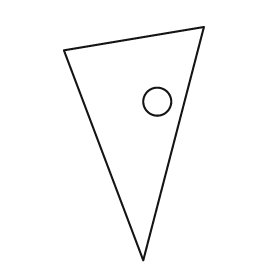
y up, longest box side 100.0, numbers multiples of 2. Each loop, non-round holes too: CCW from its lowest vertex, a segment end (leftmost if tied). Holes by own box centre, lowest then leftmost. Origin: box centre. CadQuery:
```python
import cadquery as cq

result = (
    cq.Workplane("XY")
    .moveTo(4.0, -50.0)
    .lineTo(30.0, 50.0)
    .lineTo(-30.0, 40.0)
    .close()
    .moveTo(10.0, 18.0)
    .circle(6.0)
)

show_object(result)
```